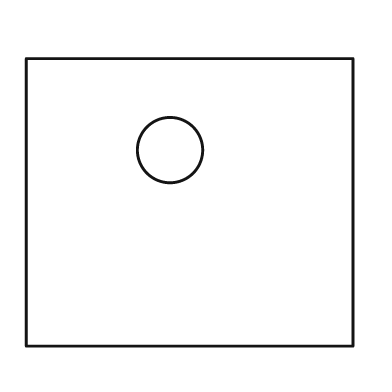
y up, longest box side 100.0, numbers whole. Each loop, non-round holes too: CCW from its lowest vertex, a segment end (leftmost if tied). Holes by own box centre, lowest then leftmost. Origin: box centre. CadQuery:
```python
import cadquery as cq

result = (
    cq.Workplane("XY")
    .moveTo(-50.0, -44.0)
    .lineTo(50.0, -44.0)
    .lineTo(50.0, 44.0)
    .lineTo(-50.0, 44.0)
    .close()
    .moveTo(-6.0, 16.0)
    .circle(10.0)
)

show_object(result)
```